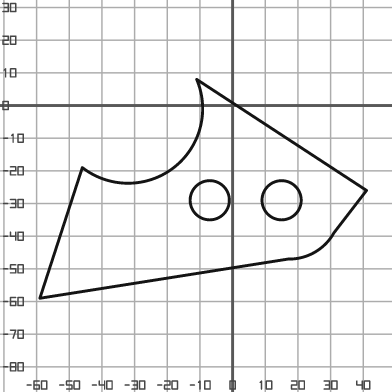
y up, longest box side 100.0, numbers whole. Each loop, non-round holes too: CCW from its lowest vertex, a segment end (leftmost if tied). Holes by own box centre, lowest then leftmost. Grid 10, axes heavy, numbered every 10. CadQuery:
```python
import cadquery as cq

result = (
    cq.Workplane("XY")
    .moveTo(-59.0, -59.0)
    .lineTo(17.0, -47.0)
    .threePointArc((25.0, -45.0), (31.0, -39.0))
    .lineTo(41.0, -26.0)
    .lineTo(-11.0, 8.0)
    .threePointArc((-18.0, -19.0), (-46.0, -19.0))
    .close()
    .moveTo(-7.0, -29.0)
    .circle(6.0)
    .moveTo(15.0, -29.0)
    .circle(6.0)
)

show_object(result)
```